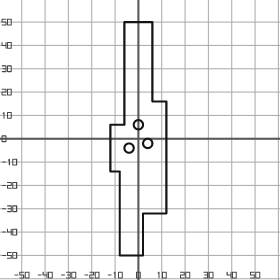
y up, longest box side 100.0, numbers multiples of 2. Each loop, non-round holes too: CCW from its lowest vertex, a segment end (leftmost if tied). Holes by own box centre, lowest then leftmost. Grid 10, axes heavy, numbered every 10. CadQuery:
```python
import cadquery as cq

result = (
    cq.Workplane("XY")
    .moveTo(-8.0, -50.0)
    .lineTo(2.0, -50.0)
    .lineTo(2.0, -32.0)
    .lineTo(12.0, -32.0)
    .lineTo(12.0, 16.0)
    .lineTo(6.0, 16.0)
    .lineTo(6.0, 50.0)
    .lineTo(-6.0, 50.0)
    .lineTo(-6.0, 6.0)
    .lineTo(-12.0, 6.0)
    .lineTo(-12.0, -14.0)
    .lineTo(-8.0, -14.0)
    .close()
    .moveTo(-4.0, -4.0)
    .circle(2.0)
    .moveTo(4.0, -2.0)
    .circle(2.0)
    .moveTo(0.0, 6.0)
    .circle(2.0)
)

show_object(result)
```